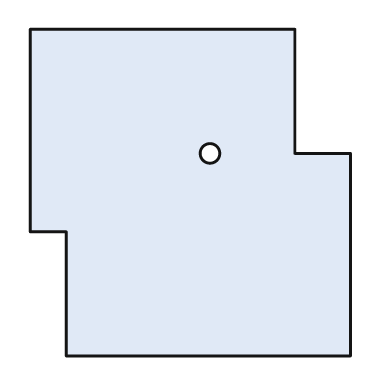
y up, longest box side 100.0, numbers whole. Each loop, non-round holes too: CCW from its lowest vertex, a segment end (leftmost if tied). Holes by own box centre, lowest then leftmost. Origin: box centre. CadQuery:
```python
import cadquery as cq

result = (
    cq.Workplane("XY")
    .moveTo(-38.0, -50.0)
    .lineTo(49.0, -50.0)
    .lineTo(49.0, 12.0)
    .lineTo(32.0, 12.0)
    .lineTo(32.0, 50.0)
    .lineTo(-49.0, 50.0)
    .lineTo(-49.0, -12.0)
    .lineTo(-38.0, -12.0)
    .close()
    .moveTo(6.0, 12.0)
    .circle(3.0)
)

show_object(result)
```